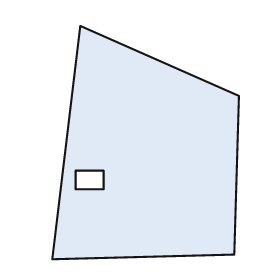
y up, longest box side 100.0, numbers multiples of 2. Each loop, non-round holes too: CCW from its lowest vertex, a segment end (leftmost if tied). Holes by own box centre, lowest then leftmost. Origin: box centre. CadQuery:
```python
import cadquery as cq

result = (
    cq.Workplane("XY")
    .moveTo(-40.0, -50.0)
    .lineTo(38.0, -48.0)
    .lineTo(40.0, 20.0)
    .lineTo(-28.0, 50.0)
    .close()
    .moveTo(-30.0, -20.0)
    .lineTo(-18.0, -20.0)
    .lineTo(-18.0, -12.0)
    .lineTo(-30.0, -12.0)
    .close()
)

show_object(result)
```